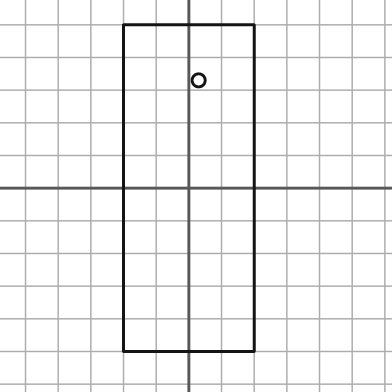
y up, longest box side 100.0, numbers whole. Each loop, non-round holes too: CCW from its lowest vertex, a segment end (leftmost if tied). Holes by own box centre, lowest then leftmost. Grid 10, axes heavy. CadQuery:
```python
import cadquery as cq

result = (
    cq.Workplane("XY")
    .moveTo(-20.0, -50.0)
    .lineTo(20.0, -50.0)
    .lineTo(20.0, 50.0)
    .lineTo(-20.0, 50.0)
    .close()
    .moveTo(3.0, 33.0)
    .circle(2.0)
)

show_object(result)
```